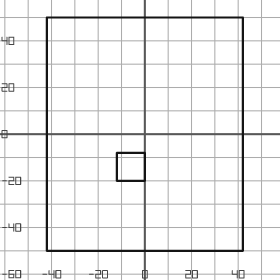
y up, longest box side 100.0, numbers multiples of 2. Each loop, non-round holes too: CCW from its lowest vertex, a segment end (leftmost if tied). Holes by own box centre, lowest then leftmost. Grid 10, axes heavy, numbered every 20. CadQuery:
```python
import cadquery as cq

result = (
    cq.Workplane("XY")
    .moveTo(-42.0, -50.0)
    .lineTo(42.0, -50.0)
    .lineTo(42.0, 50.0)
    .lineTo(-42.0, 50.0)
    .close()
    .moveTo(-12.0, -20.0)
    .lineTo(0.0, -20.0)
    .lineTo(0.0, -8.0)
    .lineTo(-12.0, -8.0)
    .close()
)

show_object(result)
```